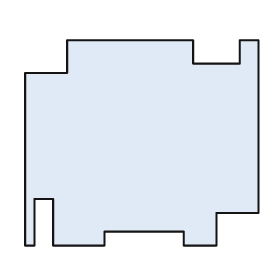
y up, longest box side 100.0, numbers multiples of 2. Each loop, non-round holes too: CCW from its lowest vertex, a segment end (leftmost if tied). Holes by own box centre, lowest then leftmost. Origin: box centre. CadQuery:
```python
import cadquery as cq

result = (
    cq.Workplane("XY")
    .moveTo(-50.0, -44.0)
    .lineTo(-46.0, -44.0)
    .lineTo(-46.0, -24.0)
    .lineTo(-38.0, -24.0)
    .lineTo(-38.0, -44.0)
    .lineTo(-16.0, -44.0)
    .lineTo(-16.0, -38.0)
    .lineTo(18.0, -38.0)
    .lineTo(18.0, -44.0)
    .lineTo(32.0, -44.0)
    .lineTo(32.0, -30.0)
    .lineTo(50.0, -30.0)
    .lineTo(50.0, 44.0)
    .lineTo(42.0, 44.0)
    .lineTo(42.0, 34.0)
    .lineTo(22.0, 34.0)
    .lineTo(22.0, 44.0)
    .lineTo(-32.0, 44.0)
    .lineTo(-32.0, 30.0)
    .lineTo(-50.0, 30.0)
    .close()
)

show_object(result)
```